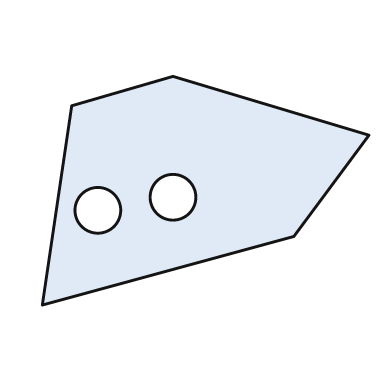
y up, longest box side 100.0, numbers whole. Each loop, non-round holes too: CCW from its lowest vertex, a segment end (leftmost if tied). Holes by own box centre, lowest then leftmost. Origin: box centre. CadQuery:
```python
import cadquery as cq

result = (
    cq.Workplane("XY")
    .moveTo(-50.0, -35.0)
    .lineTo(27.0, -14.0)
    .lineTo(50.0, 17.0)
    .lineTo(-10.0, 35.0)
    .lineTo(-41.0, 26.0)
    .close()
    .moveTo(-33.0, -6.0)
    .circle(7.0)
    .moveTo(-10.0, -2.0)
    .circle(7.0)
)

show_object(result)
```